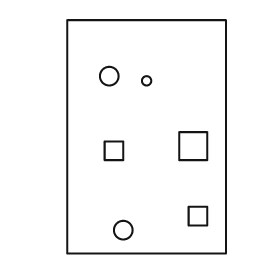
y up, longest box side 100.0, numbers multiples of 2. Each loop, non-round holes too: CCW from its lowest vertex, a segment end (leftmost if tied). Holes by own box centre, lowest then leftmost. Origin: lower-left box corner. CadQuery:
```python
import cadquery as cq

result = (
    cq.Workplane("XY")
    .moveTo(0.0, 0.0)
    .lineTo(68.0, 0.0)
    .lineTo(68.0, 100.0)
    .lineTo(0.0, 100.0)
    .close()
    .moveTo(24.0, 10.0)
    .circle(4.0)
    .moveTo(52.0, 12.0)
    .lineTo(60.0, 12.0)
    .lineTo(60.0, 20.0)
    .lineTo(52.0, 20.0)
    .close()
    .moveTo(16.0, 40.0)
    .lineTo(24.0, 40.0)
    .lineTo(24.0, 48.0)
    .lineTo(16.0, 48.0)
    .close()
    .moveTo(48.0, 40.0)
    .lineTo(60.0, 40.0)
    .lineTo(60.0, 52.0)
    .lineTo(48.0, 52.0)
    .close()
    .moveTo(34.0, 74.0)
    .circle(2.0)
    .moveTo(18.0, 76.0)
    .circle(4.0)
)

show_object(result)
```